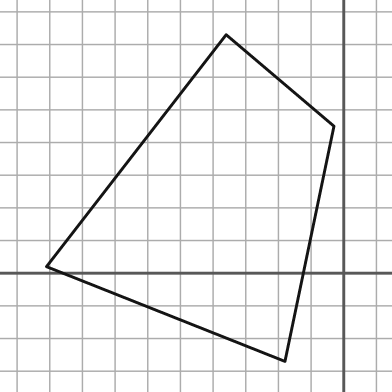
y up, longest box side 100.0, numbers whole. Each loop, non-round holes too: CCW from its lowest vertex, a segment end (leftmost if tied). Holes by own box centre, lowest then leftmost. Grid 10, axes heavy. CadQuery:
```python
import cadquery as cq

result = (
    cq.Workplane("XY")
    .moveTo(-18.0, -27.0)
    .lineTo(-3.0, 45.0)
    .lineTo(-36.0, 73.0)
    .lineTo(-91.0, 2.0)
    .close()
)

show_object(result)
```